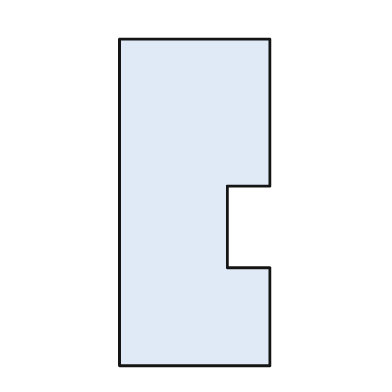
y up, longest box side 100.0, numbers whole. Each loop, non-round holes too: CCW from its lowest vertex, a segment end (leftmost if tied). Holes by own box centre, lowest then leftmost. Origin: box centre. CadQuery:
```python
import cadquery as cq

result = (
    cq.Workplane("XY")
    .moveTo(-23.0, -50.0)
    .lineTo(23.0, -50.0)
    .lineTo(23.0, -20.0)
    .lineTo(10.0, -20.0)
    .lineTo(10.0, 5.0)
    .lineTo(23.0, 5.0)
    .lineTo(23.0, 50.0)
    .lineTo(-23.0, 50.0)
    .close()
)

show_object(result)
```